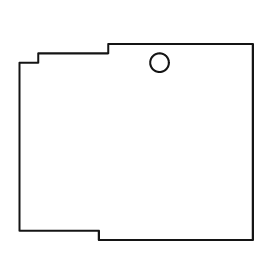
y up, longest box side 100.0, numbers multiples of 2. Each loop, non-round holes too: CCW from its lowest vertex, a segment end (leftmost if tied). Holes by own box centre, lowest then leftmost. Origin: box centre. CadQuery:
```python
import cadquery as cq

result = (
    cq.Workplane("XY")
    .moveTo(-16.0, -42.0)
    .lineTo(50.0, -42.0)
    .lineTo(50.0, 42.0)
    .lineTo(-12.0, 42.0)
    .lineTo(-12.0, 38.0)
    .lineTo(-42.0, 38.0)
    .lineTo(-42.0, 34.0)
    .lineTo(-50.0, 34.0)
    .lineTo(-50.0, -38.0)
    .lineTo(-16.0, -38.0)
    .close()
    .moveTo(10.0, 34.0)
    .circle(4.0)
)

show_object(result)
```